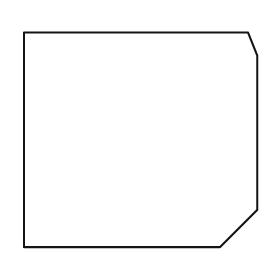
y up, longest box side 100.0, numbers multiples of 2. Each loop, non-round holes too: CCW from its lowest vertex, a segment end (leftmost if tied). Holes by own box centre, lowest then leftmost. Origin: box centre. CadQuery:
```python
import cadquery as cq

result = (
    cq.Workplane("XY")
    .moveTo(-50.0, -46.0)
    .lineTo(34.0, -46.0)
    .lineTo(50.0, -30.0)
    .lineTo(50.0, 36.0)
    .lineTo(46.0, 46.0)
    .lineTo(-50.0, 46.0)
    .close()
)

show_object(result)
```